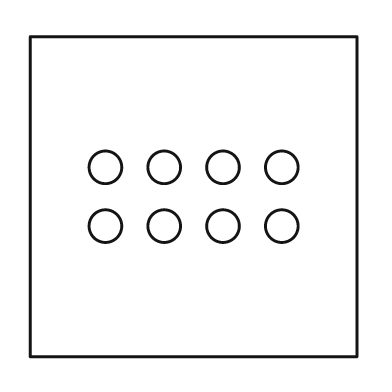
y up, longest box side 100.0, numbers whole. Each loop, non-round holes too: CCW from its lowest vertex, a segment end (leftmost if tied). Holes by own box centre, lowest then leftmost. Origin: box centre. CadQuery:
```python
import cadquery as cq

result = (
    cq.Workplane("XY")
    .moveTo(-50.0, -49.0)
    .lineTo(50.0, -49.0)
    .lineTo(50.0, 49.0)
    .lineTo(-50.0, 49.0)
    .close()
    .moveTo(-27.0, -9.0)
    .circle(5.0)
    .moveTo(-9.0, -9.0)
    .circle(5.0)
    .moveTo(9.0, -9.0)
    .circle(5.0)
    .moveTo(27.0, -9.0)
    .circle(5.0)
    .moveTo(-27.0, 9.0)
    .circle(5.0)
    .moveTo(-9.0, 9.0)
    .circle(5.0)
    .moveTo(9.0, 9.0)
    .circle(5.0)
    .moveTo(27.0, 9.0)
    .circle(5.0)
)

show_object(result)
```